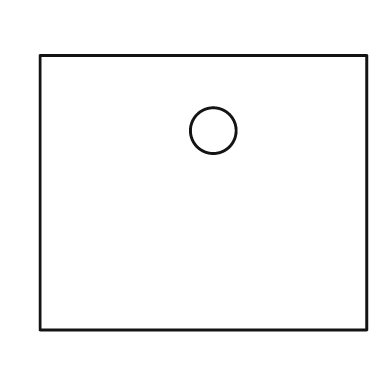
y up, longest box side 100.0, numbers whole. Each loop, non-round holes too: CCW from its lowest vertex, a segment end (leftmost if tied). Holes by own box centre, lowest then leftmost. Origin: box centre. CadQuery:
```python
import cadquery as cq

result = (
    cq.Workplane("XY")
    .moveTo(-50.0, -42.0)
    .lineTo(50.0, -42.0)
    .lineTo(50.0, 42.0)
    .lineTo(-50.0, 42.0)
    .close()
    .moveTo(3.0, 19.0)
    .circle(7.0)
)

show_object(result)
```